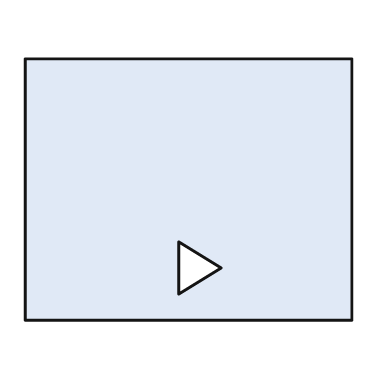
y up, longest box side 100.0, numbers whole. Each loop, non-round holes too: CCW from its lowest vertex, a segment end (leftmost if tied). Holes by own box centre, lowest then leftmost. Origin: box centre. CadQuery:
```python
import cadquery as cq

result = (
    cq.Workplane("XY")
    .moveTo(-50.0, -40.0)
    .lineTo(50.0, -40.0)
    .lineTo(50.0, 40.0)
    .lineTo(-50.0, 40.0)
    .close()
    .moveTo(-3.0, -32.0)
    .lineTo(10.0, -24.0)
    .lineTo(-3.0, -16.0)
    .close()
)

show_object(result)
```